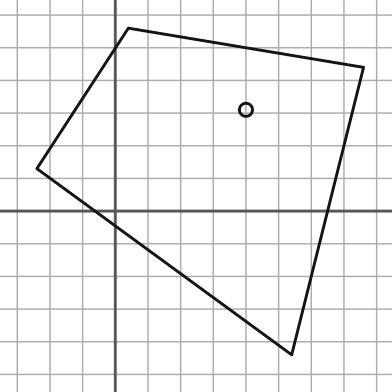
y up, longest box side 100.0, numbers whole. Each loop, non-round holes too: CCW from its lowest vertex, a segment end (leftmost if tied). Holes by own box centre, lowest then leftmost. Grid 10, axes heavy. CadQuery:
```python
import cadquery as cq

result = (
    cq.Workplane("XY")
    .moveTo(54.0, -44.0)
    .lineTo(76.0, 44.0)
    .lineTo(4.0, 56.0)
    .lineTo(-24.0, 13.0)
    .close()
    .moveTo(40.0, 31.0)
    .circle(2.0)
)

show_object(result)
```